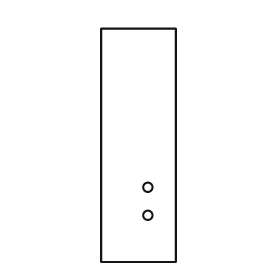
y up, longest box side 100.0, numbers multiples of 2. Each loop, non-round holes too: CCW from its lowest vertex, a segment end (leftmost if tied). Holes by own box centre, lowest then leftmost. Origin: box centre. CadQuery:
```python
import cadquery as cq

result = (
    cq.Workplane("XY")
    .moveTo(-16.0, -50.0)
    .lineTo(16.0, -50.0)
    .lineTo(16.0, 50.0)
    .lineTo(-16.0, 50.0)
    .close()
    .moveTo(4.0, -30.0)
    .circle(2.0)
    .moveTo(4.0, -18.0)
    .circle(2.0)
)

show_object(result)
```